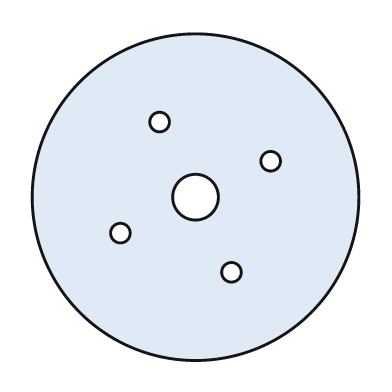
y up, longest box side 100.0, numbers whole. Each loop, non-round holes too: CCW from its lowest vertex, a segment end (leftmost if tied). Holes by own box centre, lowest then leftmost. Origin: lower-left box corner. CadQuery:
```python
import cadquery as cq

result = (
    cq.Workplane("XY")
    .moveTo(50.0, 50.0)
    .circle(50.0)
    .moveTo(61.0, 27.0)
    .circle(3.0)
    .moveTo(27.0, 39.0)
    .circle(3.0)
    .moveTo(50.0, 50.0)
    .circle(7.0)
    .moveTo(73.0, 61.0)
    .circle(3.0)
    .moveTo(39.0, 73.0)
    .circle(3.0)
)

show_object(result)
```